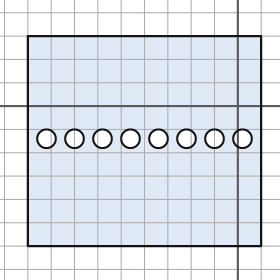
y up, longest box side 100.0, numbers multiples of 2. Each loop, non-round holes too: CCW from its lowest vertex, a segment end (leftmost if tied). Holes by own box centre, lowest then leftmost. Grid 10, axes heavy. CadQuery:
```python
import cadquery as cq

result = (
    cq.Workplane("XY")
    .moveTo(-90.0, -60.0)
    .lineTo(10.0, -60.0)
    .lineTo(10.0, 30.0)
    .lineTo(-90.0, 30.0)
    .close()
    .moveTo(-82.0, -14.0)
    .circle(4.0)
    .moveTo(-70.0, -14.0)
    .circle(4.0)
    .moveTo(-58.0, -14.0)
    .circle(4.0)
    .moveTo(-46.0, -14.0)
    .circle(4.0)
    .moveTo(-34.0, -14.0)
    .circle(4.0)
    .moveTo(-22.0, -14.0)
    .circle(4.0)
    .moveTo(-10.0, -14.0)
    .circle(4.0)
    .moveTo(2.0, -14.0)
    .circle(4.0)
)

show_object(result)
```